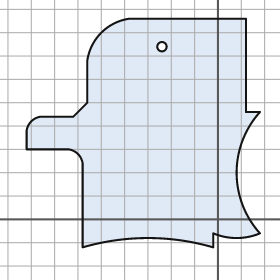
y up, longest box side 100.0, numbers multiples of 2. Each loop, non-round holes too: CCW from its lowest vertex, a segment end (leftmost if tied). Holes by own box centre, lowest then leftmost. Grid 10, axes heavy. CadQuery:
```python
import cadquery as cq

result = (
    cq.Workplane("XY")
    .moveTo(-58.0, -12.0)
    .threePointArc((-30.0, -8.0), (-2.0, -12.0))
    .lineTo(-2.0, -6.0)
    .threePointArc((8.0, -8.0), (18.0, -6.0))
    .threePointArc((8.0, 20.0), (18.0, 46.0))
    .lineTo(12.0, 46.0)
    .lineTo(12.0, 86.0)
    .lineTo(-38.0, 86.0)
    .threePointArc((-50.0, 80.0), (-56.0, 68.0))
    .lineTo(-56.0, 50.0)
    .lineTo(-62.0, 44.0)
    .lineTo(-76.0, 44.0)
    .threePointArc((-80.0, 42.0), (-82.0, 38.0))
    .lineTo(-82.0, 30.0)
    .lineTo(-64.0, 30.0)
    .threePointArc((-60.0, 28.0), (-58.0, 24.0))
    .close()
    .moveTo(-24.0, 74.0)
    .circle(2.0)
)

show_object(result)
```